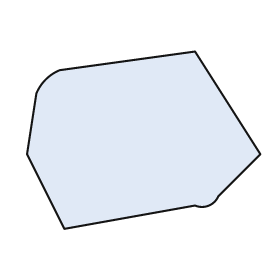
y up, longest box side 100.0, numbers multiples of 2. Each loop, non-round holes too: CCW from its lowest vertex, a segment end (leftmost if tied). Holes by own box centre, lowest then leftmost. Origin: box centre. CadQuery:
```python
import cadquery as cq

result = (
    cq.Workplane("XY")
    .moveTo(-34.0, -38.0)
    .lineTo(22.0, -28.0)
    .threePointArc((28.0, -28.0), (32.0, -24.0))
    .lineTo(50.0, -6.0)
    .lineTo(22.0, 38.0)
    .lineTo(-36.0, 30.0)
    .threePointArc((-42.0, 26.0), (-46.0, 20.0))
    .lineTo(-50.0, -6.0)
    .close()
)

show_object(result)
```